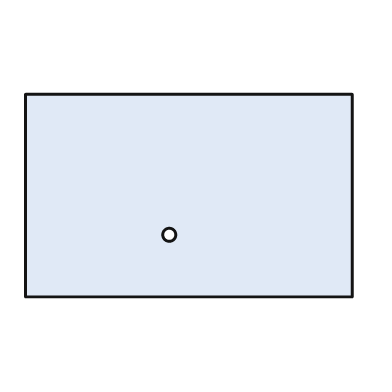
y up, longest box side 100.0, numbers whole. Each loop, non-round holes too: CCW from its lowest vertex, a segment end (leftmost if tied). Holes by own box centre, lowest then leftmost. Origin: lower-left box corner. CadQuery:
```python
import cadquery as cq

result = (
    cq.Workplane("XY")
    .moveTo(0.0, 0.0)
    .lineTo(100.0, 0.0)
    .lineTo(100.0, 62.0)
    .lineTo(0.0, 62.0)
    .close()
    .moveTo(44.0, 19.0)
    .circle(2.0)
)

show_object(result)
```